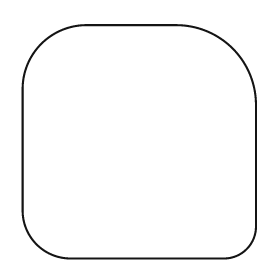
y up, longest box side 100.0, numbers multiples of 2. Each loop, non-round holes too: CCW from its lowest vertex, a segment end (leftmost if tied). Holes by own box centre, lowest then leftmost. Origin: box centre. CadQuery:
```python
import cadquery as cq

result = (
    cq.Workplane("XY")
    .moveTo(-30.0, -50.0)
    .lineTo(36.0, -50.0)
    .threePointArc((46.0, -46.0), (50.0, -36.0))
    .lineTo(50.0, 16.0)
    .threePointArc((40.0, 40.0), (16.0, 50.0))
    .lineTo(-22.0, 50.0)
    .threePointArc((-42.0, 42.0), (-50.0, 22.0))
    .lineTo(-50.0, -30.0)
    .threePointArc((-44.0, -44.0), (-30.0, -50.0))
    .close()
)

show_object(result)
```